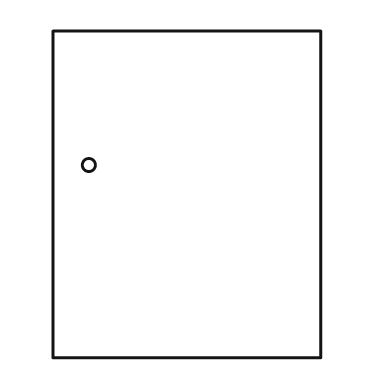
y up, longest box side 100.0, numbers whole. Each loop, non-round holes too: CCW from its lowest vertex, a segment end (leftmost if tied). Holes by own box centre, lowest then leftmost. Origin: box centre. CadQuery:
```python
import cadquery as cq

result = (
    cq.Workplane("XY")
    .moveTo(-41.0, -50.0)
    .lineTo(41.0, -50.0)
    .lineTo(41.0, 50.0)
    .lineTo(-41.0, 50.0)
    .close()
    .moveTo(-30.0, 9.0)
    .circle(2.0)
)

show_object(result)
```